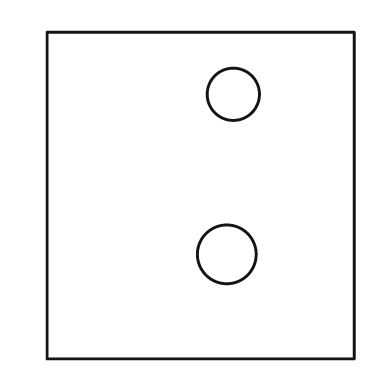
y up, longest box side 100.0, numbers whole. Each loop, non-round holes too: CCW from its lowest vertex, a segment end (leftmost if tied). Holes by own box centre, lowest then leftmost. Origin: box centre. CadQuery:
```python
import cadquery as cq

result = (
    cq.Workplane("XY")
    .moveTo(-47.0, -50.0)
    .lineTo(47.0, -50.0)
    .lineTo(47.0, 50.0)
    .lineTo(-47.0, 50.0)
    .close()
    .moveTo(8.0, -18.0)
    .circle(9.0)
    .moveTo(10.0, 31.0)
    .circle(8.0)
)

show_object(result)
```